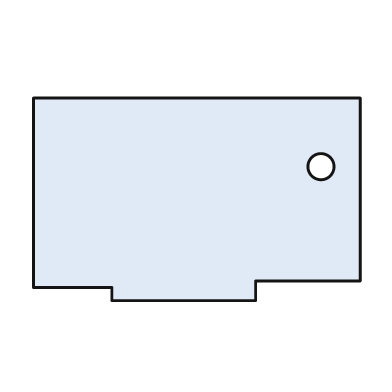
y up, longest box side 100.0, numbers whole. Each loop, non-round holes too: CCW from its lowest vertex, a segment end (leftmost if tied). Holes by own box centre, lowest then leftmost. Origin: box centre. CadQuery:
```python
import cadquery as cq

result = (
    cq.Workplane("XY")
    .moveTo(-26.0, -31.0)
    .lineTo(18.0, -31.0)
    .lineTo(18.0, -25.0)
    .lineTo(50.0, -25.0)
    .lineTo(50.0, 31.0)
    .lineTo(-50.0, 31.0)
    .lineTo(-50.0, -27.0)
    .lineTo(-26.0, -27.0)
    .close()
    .moveTo(38.0, 10.0)
    .circle(4.0)
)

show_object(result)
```